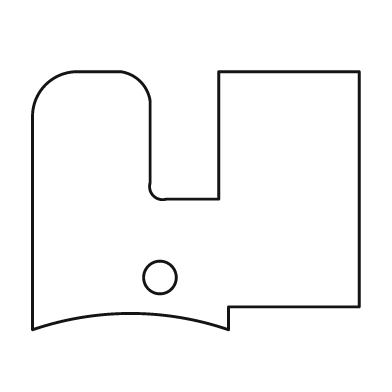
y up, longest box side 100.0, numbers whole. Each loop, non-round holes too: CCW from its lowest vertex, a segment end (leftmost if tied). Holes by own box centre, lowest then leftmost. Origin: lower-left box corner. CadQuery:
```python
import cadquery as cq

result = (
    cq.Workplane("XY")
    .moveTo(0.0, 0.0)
    .threePointArc((30.0, 5.0), (60.0, 0.0))
    .lineTo(60.0, 7.0)
    .lineTo(100.0, 7.0)
    .lineTo(100.0, 79.0)
    .lineTo(57.0, 79.0)
    .lineTo(57.0, 40.0)
    .lineTo(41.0, 40.0)
    .threePointArc((37.0, 41.0), (36.0, 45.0))
    .lineTo(36.0, 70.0)
    .threePointArc((33.0, 76.0), (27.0, 79.0))
    .lineTo(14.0, 79.0)
    .threePointArc((4.0, 75.0), (0.0, 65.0))
    .close()
    .moveTo(39.0, 16.0)
    .circle(5.0)
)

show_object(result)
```